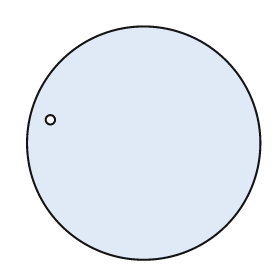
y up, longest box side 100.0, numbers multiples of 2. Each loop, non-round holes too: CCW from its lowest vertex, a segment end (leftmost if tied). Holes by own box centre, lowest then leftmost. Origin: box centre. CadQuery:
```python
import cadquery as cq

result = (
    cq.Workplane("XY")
    .moveTo(0.0, 0.0)
    .circle(50.0)
    .moveTo(-40.0, 10.0)
    .circle(2.0)
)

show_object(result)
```